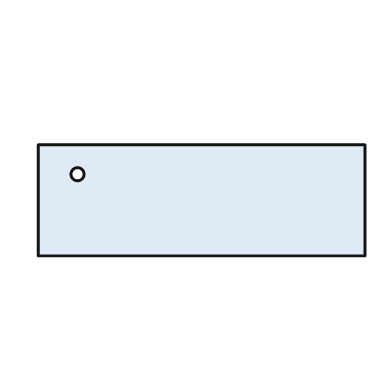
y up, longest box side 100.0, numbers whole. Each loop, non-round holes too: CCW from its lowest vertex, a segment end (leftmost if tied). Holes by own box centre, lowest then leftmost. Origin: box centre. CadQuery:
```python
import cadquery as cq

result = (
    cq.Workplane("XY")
    .moveTo(-50.0, -17.0)
    .lineTo(50.0, -17.0)
    .lineTo(50.0, 17.0)
    .lineTo(-50.0, 17.0)
    .close()
    .moveTo(-38.0, 8.0)
    .circle(2.0)
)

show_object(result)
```